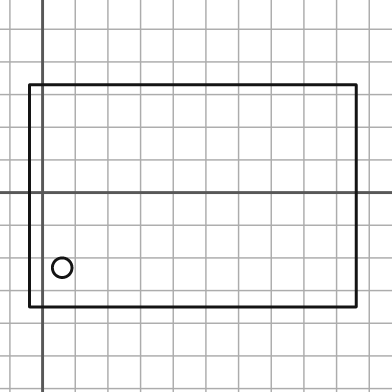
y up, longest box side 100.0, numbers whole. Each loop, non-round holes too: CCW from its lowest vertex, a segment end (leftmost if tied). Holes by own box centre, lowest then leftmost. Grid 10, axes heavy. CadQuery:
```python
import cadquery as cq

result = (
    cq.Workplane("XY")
    .moveTo(-4.0, -35.0)
    .lineTo(96.0, -35.0)
    .lineTo(96.0, 33.0)
    .lineTo(-4.0, 33.0)
    .close()
    .moveTo(6.0, -23.0)
    .circle(3.0)
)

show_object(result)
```